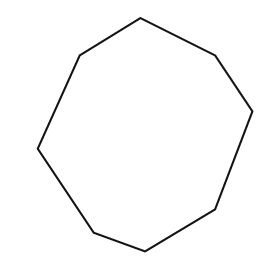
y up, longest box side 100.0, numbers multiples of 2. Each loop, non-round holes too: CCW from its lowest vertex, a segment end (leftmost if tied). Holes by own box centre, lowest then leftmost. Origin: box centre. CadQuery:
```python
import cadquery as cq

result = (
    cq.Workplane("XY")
    .moveTo(0.0, -50.0)
    .lineTo(30.0, -32.0)
    .lineTo(46.0, 10.0)
    .lineTo(30.0, 34.0)
    .lineTo(-2.0, 50.0)
    .lineTo(-28.0, 34.0)
    .lineTo(-46.0, -6.0)
    .lineTo(-22.0, -42.0)
    .close()
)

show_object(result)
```